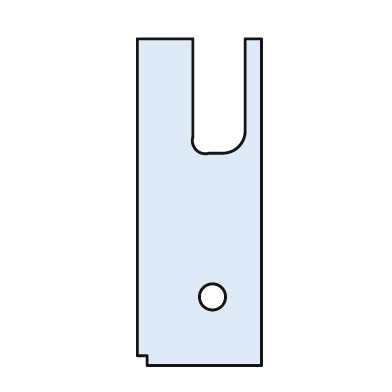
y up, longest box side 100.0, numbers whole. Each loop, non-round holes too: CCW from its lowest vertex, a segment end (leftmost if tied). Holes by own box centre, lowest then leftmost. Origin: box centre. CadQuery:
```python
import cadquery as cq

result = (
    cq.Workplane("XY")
    .moveTo(-16.0, -50.0)
    .lineTo(19.0, -50.0)
    .lineTo(19.0, 50.0)
    .lineTo(14.0, 50.0)
    .lineTo(14.0, 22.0)
    .threePointArc((12.0, 17.0), (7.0, 15.0))
    .lineTo(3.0, 15.0)
    .threePointArc((-1.0, 16.0), (-2.0, 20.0))
    .lineTo(-2.0, 50.0)
    .lineTo(-19.0, 50.0)
    .lineTo(-19.0, -47.0)
    .lineTo(-16.0, -47.0)
    .close()
    .moveTo(4.0, -29.0)
    .circle(4.0)
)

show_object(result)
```